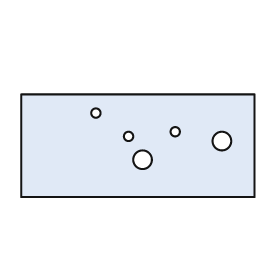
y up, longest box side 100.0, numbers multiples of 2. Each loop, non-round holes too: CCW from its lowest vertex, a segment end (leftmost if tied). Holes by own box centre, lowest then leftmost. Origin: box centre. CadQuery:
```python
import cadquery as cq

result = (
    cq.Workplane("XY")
    .moveTo(-50.0, -22.0)
    .lineTo(50.0, -22.0)
    .lineTo(50.0, 22.0)
    .lineTo(-50.0, 22.0)
    .close()
    .moveTo(2.0, -6.0)
    .circle(4.0)
    .moveTo(36.0, 2.0)
    .circle(4.0)
    .moveTo(-4.0, 4.0)
    .circle(2.0)
    .moveTo(16.0, 6.0)
    .circle(2.0)
    .moveTo(-18.0, 14.0)
    .circle(2.0)
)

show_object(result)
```